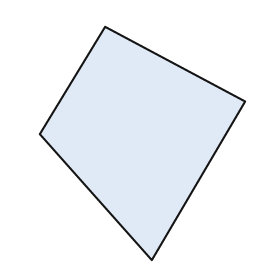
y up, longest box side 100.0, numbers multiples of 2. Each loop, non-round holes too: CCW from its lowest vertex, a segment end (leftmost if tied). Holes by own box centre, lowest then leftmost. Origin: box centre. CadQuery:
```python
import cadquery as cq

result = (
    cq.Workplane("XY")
    .moveTo(4.0, -50.0)
    .lineTo(44.0, 18.0)
    .lineTo(-16.0, 50.0)
    .lineTo(-44.0, 4.0)
    .close()
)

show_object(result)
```